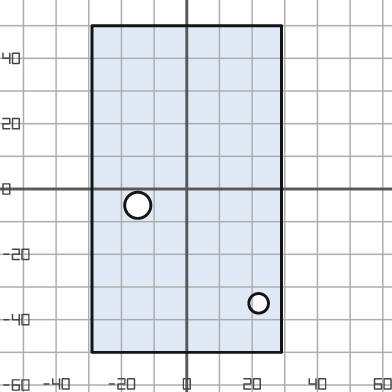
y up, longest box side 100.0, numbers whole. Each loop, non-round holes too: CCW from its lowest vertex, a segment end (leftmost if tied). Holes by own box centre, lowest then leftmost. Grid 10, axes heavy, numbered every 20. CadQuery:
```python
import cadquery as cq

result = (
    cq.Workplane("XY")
    .moveTo(-29.0, -50.0)
    .lineTo(29.0, -50.0)
    .lineTo(29.0, 50.0)
    .lineTo(-29.0, 50.0)
    .close()
    .moveTo(22.0, -35.0)
    .circle(3.0)
    .moveTo(-15.0, -5.0)
    .circle(4.0)
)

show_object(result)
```